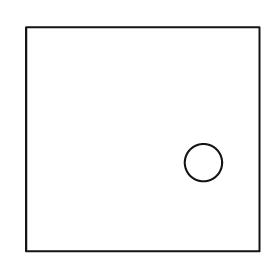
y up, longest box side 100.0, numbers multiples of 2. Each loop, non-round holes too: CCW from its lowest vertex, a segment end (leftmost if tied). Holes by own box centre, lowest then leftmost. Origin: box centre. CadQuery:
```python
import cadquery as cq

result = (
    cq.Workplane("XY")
    .moveTo(-50.0, -48.0)
    .lineTo(50.0, -48.0)
    .lineTo(50.0, 48.0)
    .lineTo(-50.0, 48.0)
    .close()
    .moveTo(26.0, -10.0)
    .circle(8.0)
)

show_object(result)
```